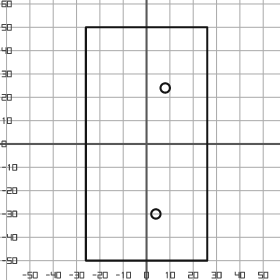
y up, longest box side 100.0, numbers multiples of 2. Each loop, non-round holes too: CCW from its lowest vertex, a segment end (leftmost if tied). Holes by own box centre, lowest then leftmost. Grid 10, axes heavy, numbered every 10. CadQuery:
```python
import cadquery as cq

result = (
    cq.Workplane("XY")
    .moveTo(-26.0, -50.0)
    .lineTo(26.0, -50.0)
    .lineTo(26.0, 50.0)
    .lineTo(-26.0, 50.0)
    .close()
    .moveTo(4.0, -30.0)
    .circle(2.0)
    .moveTo(8.0, 24.0)
    .circle(2.0)
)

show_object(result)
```